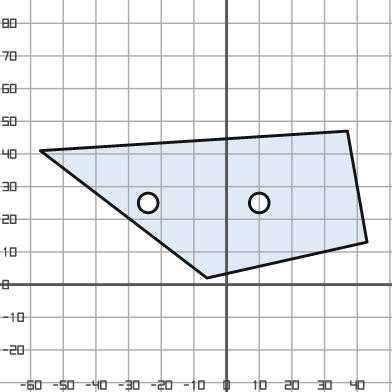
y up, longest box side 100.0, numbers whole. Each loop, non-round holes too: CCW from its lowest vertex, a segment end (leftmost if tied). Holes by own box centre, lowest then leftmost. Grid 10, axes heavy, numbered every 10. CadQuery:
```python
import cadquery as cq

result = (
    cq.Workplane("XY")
    .moveTo(-6.0, 2.0)
    .lineTo(43.0, 13.0)
    .lineTo(37.0, 47.0)
    .lineTo(-57.0, 41.0)
    .close()
    .moveTo(-24.0, 25.0)
    .circle(3.0)
    .moveTo(10.0, 25.0)
    .circle(3.0)
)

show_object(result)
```